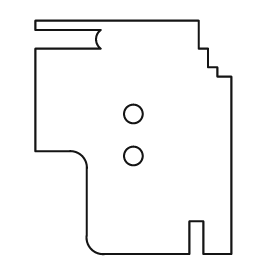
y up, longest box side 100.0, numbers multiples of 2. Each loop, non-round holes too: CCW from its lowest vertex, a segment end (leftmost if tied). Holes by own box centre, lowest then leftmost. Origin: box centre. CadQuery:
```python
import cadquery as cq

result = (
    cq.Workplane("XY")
    .moveTo(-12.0, -50.0)
    .lineTo(24.0, -50.0)
    .lineTo(24.0, -36.0)
    .lineTo(30.0, -36.0)
    .lineTo(30.0, -50.0)
    .lineTo(42.0, -50.0)
    .lineTo(42.0, 26.0)
    .lineTo(36.0, 26.0)
    .lineTo(36.0, 30.0)
    .lineTo(32.0, 30.0)
    .lineTo(32.0, 38.0)
    .lineTo(28.0, 38.0)
    .lineTo(28.0, 50.0)
    .lineTo(-42.0, 50.0)
    .lineTo(-42.0, 46.0)
    .lineTo(-14.0, 46.0)
    .threePointArc((-16.0, 42.0), (-14.0, 38.0))
    .lineTo(-42.0, 38.0)
    .lineTo(-42.0, -6.0)
    .lineTo(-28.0, -6.0)
    .threePointArc((-22.0, -8.0), (-20.0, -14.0))
    .lineTo(-20.0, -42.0)
    .threePointArc((-18.0, -48.0), (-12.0, -50.0))
    .close()
    .moveTo(0.0, -8.0)
    .circle(4.0)
    .moveTo(0.0, 10.0)
    .circle(4.0)
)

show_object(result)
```